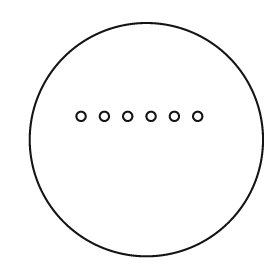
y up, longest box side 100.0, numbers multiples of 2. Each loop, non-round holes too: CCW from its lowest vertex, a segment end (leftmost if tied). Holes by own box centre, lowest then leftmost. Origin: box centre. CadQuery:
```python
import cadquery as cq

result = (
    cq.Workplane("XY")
    .moveTo(0.0, 0.0)
    .circle(50.0)
    .moveTo(-28.0, 10.0)
    .circle(2.0)
    .moveTo(-18.0, 10.0)
    .circle(2.0)
    .moveTo(-8.0, 10.0)
    .circle(2.0)
    .moveTo(2.0, 10.0)
    .circle(2.0)
    .moveTo(12.0, 10.0)
    .circle(2.0)
    .moveTo(22.0, 10.0)
    .circle(2.0)
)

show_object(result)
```